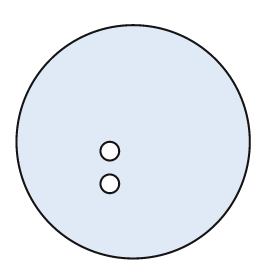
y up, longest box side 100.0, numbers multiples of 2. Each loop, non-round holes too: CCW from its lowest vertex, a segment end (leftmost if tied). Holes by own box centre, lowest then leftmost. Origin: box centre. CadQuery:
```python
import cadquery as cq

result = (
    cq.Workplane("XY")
    .moveTo(0.0, 0.0)
    .circle(50.0)
    .moveTo(-10.0, -18.0)
    .circle(4.0)
    .moveTo(-10.0, -4.0)
    .circle(4.0)
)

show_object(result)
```